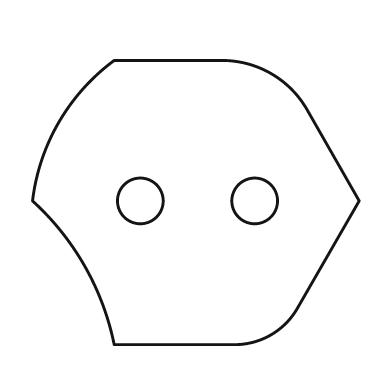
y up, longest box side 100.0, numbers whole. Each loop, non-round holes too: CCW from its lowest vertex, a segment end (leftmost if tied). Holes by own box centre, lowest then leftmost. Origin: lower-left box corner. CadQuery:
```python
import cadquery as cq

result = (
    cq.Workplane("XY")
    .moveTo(25.0, 0.0)
    .lineTo(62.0, 0.0)
    .threePointArc((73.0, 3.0), (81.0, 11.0))
    .lineTo(100.0, 44.0)
    .lineTo(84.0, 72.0)
    .threePointArc((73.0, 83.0), (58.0, 87.0))
    .lineTo(25.0, 87.0)
    .threePointArc((8.0, 68.0), (0.0, 44.0))
    .threePointArc((16.0, 24.0), (25.0, 0.0))
    .close()
    .moveTo(33.0, 44.0)
    .circle(7.0)
    .moveTo(68.0, 44.0)
    .circle(7.0)
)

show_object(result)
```